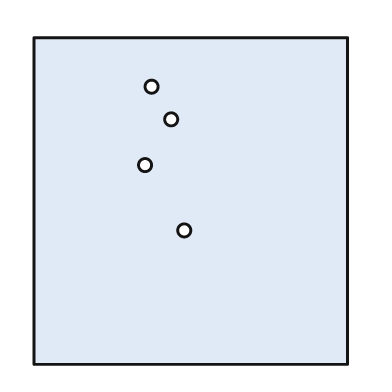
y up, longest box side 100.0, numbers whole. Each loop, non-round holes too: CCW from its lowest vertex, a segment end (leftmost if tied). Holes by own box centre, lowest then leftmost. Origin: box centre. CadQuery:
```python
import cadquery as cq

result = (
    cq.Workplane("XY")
    .moveTo(-48.0, -50.0)
    .lineTo(48.0, -50.0)
    .lineTo(48.0, 50.0)
    .lineTo(-48.0, 50.0)
    .close()
    .moveTo(-2.0, -9.0)
    .circle(2.0)
    .moveTo(-14.0, 11.0)
    .circle(2.0)
    .moveTo(-6.0, 25.0)
    .circle(2.0)
    .moveTo(-12.0, 35.0)
    .circle(2.0)
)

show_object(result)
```